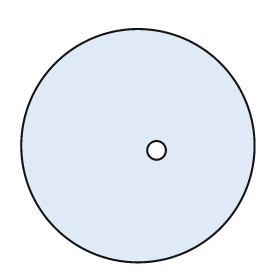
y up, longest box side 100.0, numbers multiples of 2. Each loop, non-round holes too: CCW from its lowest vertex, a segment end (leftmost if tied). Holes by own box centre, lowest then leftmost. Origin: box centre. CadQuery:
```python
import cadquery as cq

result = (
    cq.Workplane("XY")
    .moveTo(0.0, 0.0)
    .circle(50.0)
    .moveTo(8.0, -2.0)
    .circle(4.0)
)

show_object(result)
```